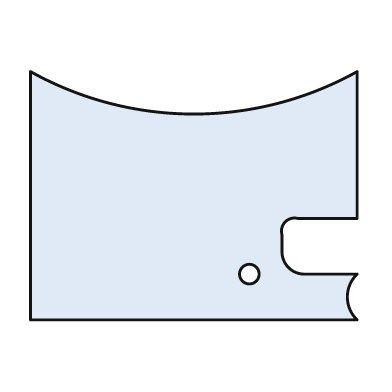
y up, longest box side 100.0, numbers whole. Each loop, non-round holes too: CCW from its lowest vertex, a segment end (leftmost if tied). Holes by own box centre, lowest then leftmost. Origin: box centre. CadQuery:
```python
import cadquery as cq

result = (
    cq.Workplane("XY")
    .moveTo(-50.0, -38.0)
    .lineTo(50.0, -38.0)
    .threePointArc((47.0, -31.0), (50.0, -24.0))
    .lineTo(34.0, -24.0)
    .threePointArc((29.0, -22.0), (27.0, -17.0))
    .lineTo(27.0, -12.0)
    .threePointArc((28.0, -8.0), (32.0, -7.0))
    .lineTo(50.0, -7.0)
    .lineTo(50.0, 38.0)
    .threePointArc((0.0, 25.0), (-50.0, 38.0))
    .close()
    .moveTo(17.0, -24.0)
    .circle(3.0)
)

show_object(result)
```